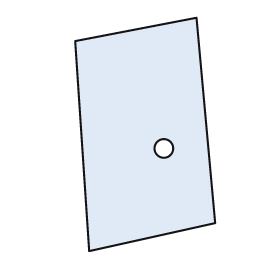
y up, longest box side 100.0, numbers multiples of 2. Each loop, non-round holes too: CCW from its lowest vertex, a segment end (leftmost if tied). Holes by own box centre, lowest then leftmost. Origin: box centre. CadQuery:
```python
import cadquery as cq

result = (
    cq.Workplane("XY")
    .moveTo(-24.0, -50.0)
    .lineTo(30.0, -38.0)
    .lineTo(22.0, 50.0)
    .lineTo(-30.0, 40.0)
    .close()
    .moveTo(8.0, -6.0)
    .circle(4.0)
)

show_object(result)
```